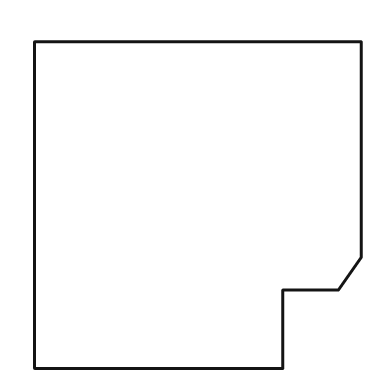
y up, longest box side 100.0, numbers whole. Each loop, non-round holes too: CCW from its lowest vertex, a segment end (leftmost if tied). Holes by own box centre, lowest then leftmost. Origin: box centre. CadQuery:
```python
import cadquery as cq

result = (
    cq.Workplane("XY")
    .moveTo(-50.0, -50.0)
    .lineTo(26.0, -50.0)
    .lineTo(26.0, -26.0)
    .lineTo(43.0, -26.0)
    .lineTo(50.0, -16.0)
    .lineTo(50.0, 50.0)
    .lineTo(-50.0, 50.0)
    .close()
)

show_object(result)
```